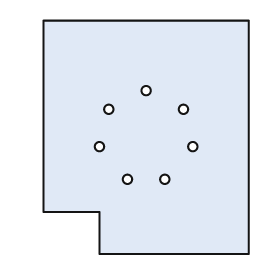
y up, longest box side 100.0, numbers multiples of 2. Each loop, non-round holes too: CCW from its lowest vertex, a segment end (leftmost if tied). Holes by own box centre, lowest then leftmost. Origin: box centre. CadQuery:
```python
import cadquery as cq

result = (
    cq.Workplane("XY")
    .moveTo(-20.0, -50.0)
    .lineTo(44.0, -50.0)
    .lineTo(44.0, 50.0)
    .lineTo(-44.0, 50.0)
    .lineTo(-44.0, -32.0)
    .lineTo(-20.0, -32.0)
    .close()
    .moveTo(-8.0, -18.0)
    .circle(2.0)
    .moveTo(8.0, -18.0)
    .circle(2.0)
    .moveTo(-20.0, -4.0)
    .circle(2.0)
    .moveTo(20.0, -4.0)
    .circle(2.0)
    .moveTo(-16.0, 12.0)
    .circle(2.0)
    .moveTo(16.0, 12.0)
    .circle(2.0)
    .moveTo(0.0, 20.0)
    .circle(2.0)
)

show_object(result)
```